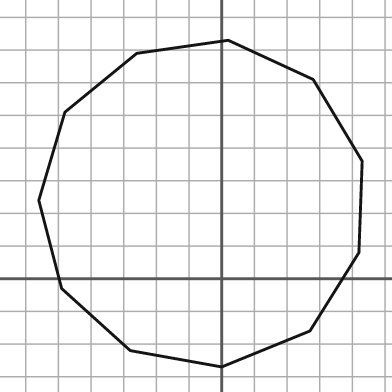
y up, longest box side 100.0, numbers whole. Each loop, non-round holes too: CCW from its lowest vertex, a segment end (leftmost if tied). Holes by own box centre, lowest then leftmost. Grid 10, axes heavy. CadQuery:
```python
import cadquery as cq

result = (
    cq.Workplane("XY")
    .moveTo(0.0, -27.0)
    .lineTo(27.0, -16.0)
    .lineTo(42.0, 8.0)
    .lineTo(43.0, 36.0)
    .lineTo(28.0, 61.0)
    .lineTo(2.0, 73.0)
    .lineTo(-26.0, 69.0)
    .lineTo(-48.0, 51.0)
    .lineTo(-56.0, 24.0)
    .lineTo(-49.0, -3.0)
    .lineTo(-28.0, -22.0)
    .close()
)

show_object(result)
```